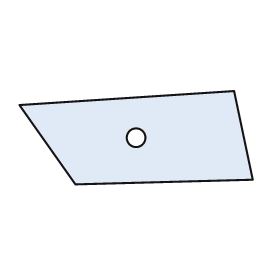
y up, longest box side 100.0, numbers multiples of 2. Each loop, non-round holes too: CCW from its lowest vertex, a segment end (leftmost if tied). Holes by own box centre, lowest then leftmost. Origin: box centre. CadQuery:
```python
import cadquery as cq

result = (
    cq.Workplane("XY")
    .moveTo(-26.0, -20.0)
    .lineTo(50.0, -18.0)
    .lineTo(42.0, 20.0)
    .lineTo(-50.0, 14.0)
    .close()
    .moveTo(0.0, 0.0)
    .circle(4.0)
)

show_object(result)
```